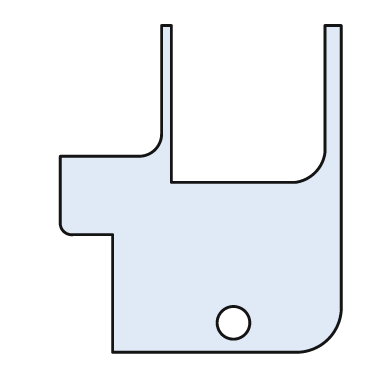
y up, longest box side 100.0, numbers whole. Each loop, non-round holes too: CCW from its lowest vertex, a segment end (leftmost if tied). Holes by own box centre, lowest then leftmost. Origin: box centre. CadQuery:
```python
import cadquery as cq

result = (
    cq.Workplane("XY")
    .moveTo(-27.0, -50.0)
    .lineTo(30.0, -50.0)
    .threePointArc((39.0, -46.0), (43.0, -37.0))
    .lineTo(43.0, 50.0)
    .lineTo(38.0, 50.0)
    .lineTo(38.0, 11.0)
    .threePointArc((35.0, 5.0), (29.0, 2.0))
    .lineTo(-9.0, 2.0)
    .lineTo(-9.0, 50.0)
    .lineTo(-12.0, 50.0)
    .lineTo(-12.0, 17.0)
    .threePointArc((-14.0, 12.0), (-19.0, 10.0))
    .lineTo(-43.0, 10.0)
    .lineTo(-43.0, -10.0)
    .threePointArc((-42.0, -13.0), (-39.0, -14.0))
    .lineTo(-27.0, -14.0)
    .close()
    .moveTo(10.0, -41.0)
    .circle(5.0)
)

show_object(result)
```